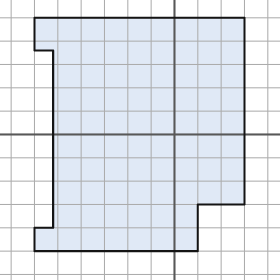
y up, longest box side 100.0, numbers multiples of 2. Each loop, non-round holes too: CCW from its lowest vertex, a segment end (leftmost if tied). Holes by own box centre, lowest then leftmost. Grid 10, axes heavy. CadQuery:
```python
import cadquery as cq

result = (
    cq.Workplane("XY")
    .moveTo(-60.0, -50.0)
    .lineTo(10.0, -50.0)
    .lineTo(10.0, -30.0)
    .lineTo(30.0, -30.0)
    .lineTo(30.0, 50.0)
    .lineTo(-60.0, 50.0)
    .lineTo(-60.0, 36.0)
    .lineTo(-52.0, 36.0)
    .lineTo(-52.0, -40.0)
    .lineTo(-60.0, -40.0)
    .close()
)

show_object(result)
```